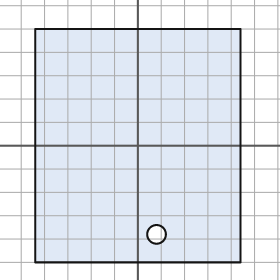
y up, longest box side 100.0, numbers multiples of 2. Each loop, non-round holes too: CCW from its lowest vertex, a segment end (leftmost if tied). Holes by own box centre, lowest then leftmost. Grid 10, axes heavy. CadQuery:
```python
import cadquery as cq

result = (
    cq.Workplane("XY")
    .moveTo(-44.0, -50.0)
    .lineTo(44.0, -50.0)
    .lineTo(44.0, 50.0)
    .lineTo(-44.0, 50.0)
    .close()
    .moveTo(8.0, -38.0)
    .circle(4.0)
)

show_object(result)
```